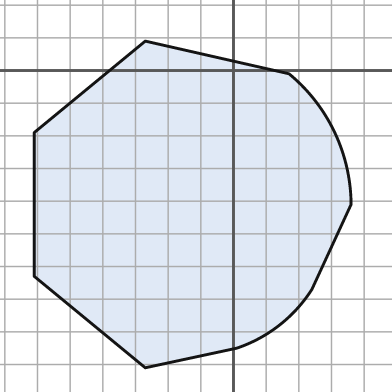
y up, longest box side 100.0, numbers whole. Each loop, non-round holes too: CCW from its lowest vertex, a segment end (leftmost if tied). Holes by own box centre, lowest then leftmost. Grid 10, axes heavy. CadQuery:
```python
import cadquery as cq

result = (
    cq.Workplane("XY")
    .moveTo(-27.0, -91.0)
    .lineTo(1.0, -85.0)
    .threePointArc((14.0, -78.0), (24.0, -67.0))
    .lineTo(36.0, -41.0)
    .threePointArc((31.0, -19.0), (17.0, -1.0))
    .lineTo(-27.0, 9.0)
    .lineTo(-61.0, -19.0)
    .lineTo(-61.0, -63.0)
    .close()
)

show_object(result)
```